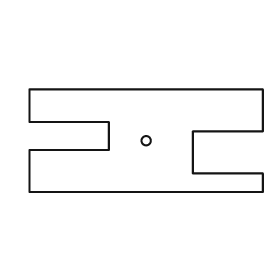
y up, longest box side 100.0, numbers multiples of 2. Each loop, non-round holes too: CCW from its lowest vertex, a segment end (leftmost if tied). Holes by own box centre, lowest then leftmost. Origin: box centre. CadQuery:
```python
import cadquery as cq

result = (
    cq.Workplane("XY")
    .moveTo(-50.0, -22.0)
    .lineTo(50.0, -22.0)
    .lineTo(50.0, -14.0)
    .lineTo(20.0, -14.0)
    .lineTo(20.0, 4.0)
    .lineTo(50.0, 4.0)
    .lineTo(50.0, 22.0)
    .lineTo(-50.0, 22.0)
    .lineTo(-50.0, 8.0)
    .lineTo(-16.0, 8.0)
    .lineTo(-16.0, -4.0)
    .lineTo(-50.0, -4.0)
    .close()
    .moveTo(0.0, 0.0)
    .circle(2.0)
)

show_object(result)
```